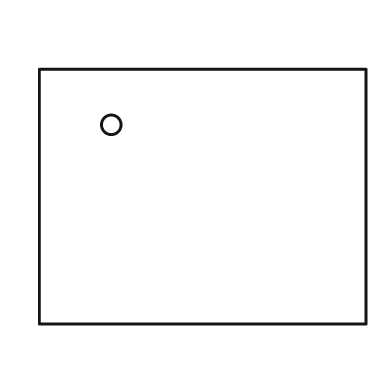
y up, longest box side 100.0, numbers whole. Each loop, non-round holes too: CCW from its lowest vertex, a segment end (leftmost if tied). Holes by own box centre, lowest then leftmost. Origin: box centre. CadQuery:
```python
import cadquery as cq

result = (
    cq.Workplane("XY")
    .moveTo(-50.0, -39.0)
    .lineTo(50.0, -39.0)
    .lineTo(50.0, 39.0)
    .lineTo(-50.0, 39.0)
    .close()
    .moveTo(-28.0, 22.0)
    .circle(3.0)
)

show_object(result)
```